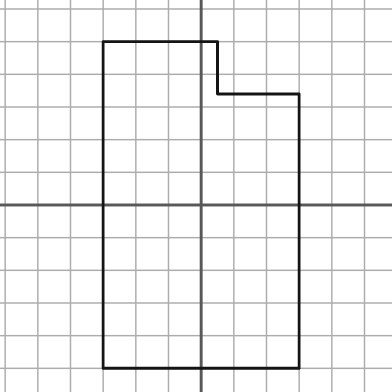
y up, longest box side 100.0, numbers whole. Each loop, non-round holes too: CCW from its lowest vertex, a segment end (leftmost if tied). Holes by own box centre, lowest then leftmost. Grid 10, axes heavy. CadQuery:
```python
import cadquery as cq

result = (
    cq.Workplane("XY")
    .moveTo(-30.0, -50.0)
    .lineTo(30.0, -50.0)
    .lineTo(30.0, 34.0)
    .lineTo(5.0, 34.0)
    .lineTo(5.0, 50.0)
    .lineTo(-30.0, 50.0)
    .close()
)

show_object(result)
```